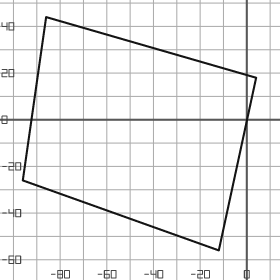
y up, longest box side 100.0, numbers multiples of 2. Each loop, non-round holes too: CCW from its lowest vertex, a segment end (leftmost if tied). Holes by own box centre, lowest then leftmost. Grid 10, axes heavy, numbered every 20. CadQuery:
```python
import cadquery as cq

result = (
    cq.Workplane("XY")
    .moveTo(-12.0, -56.0)
    .lineTo(4.0, 18.0)
    .lineTo(-86.0, 44.0)
    .lineTo(-96.0, -26.0)
    .close()
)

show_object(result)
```